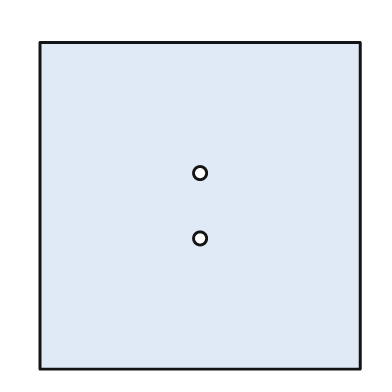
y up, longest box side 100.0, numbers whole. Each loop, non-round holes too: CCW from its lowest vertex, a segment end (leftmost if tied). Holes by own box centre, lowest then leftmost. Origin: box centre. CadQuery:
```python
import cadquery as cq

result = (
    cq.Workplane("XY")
    .moveTo(-49.0, -50.0)
    .lineTo(49.0, -50.0)
    .lineTo(49.0, 50.0)
    .lineTo(-49.0, 50.0)
    .close()
    .moveTo(0.0, -10.0)
    .circle(2.0)
    .moveTo(0.0, 10.0)
    .circle(2.0)
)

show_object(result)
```